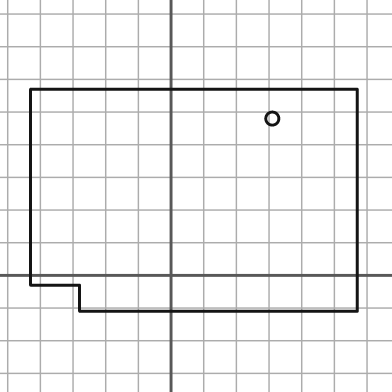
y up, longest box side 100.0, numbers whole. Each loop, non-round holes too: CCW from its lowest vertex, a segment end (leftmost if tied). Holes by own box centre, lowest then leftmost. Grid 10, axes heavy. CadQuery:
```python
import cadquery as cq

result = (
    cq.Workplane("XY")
    .moveTo(-28.0, -11.0)
    .lineTo(57.0, -11.0)
    .lineTo(57.0, 57.0)
    .lineTo(-43.0, 57.0)
    .lineTo(-43.0, -3.0)
    .lineTo(-28.0, -3.0)
    .close()
    .moveTo(31.0, 48.0)
    .circle(2.0)
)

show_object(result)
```